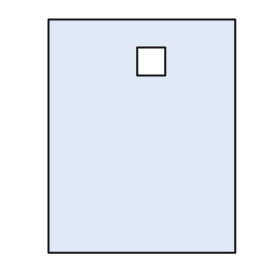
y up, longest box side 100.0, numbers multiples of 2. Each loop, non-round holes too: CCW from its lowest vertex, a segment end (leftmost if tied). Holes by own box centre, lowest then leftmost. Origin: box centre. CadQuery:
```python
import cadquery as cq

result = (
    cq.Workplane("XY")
    .moveTo(-40.0, -50.0)
    .lineTo(40.0, -50.0)
    .lineTo(40.0, 50.0)
    .lineTo(-40.0, 50.0)
    .close()
    .moveTo(-2.0, 26.0)
    .lineTo(10.0, 26.0)
    .lineTo(10.0, 38.0)
    .lineTo(-2.0, 38.0)
    .close()
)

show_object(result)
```